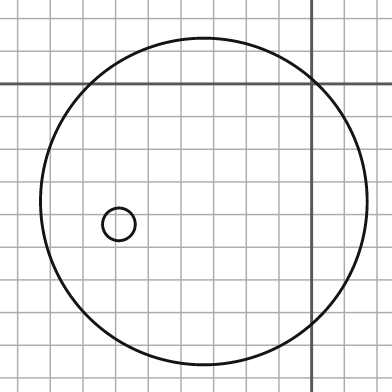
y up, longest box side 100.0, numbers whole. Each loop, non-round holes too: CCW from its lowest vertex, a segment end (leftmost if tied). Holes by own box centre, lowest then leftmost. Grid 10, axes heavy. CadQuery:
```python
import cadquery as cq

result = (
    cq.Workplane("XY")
    .moveTo(-33.0, -36.0)
    .circle(50.0)
    .moveTo(-59.0, -43.0)
    .circle(5.0)
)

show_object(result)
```